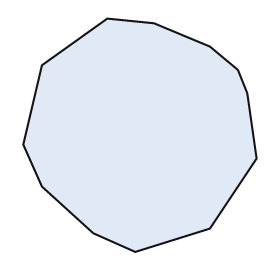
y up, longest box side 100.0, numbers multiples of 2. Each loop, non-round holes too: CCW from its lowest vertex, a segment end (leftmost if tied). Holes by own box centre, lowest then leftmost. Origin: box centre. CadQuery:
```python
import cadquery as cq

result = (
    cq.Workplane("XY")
    .moveTo(-2.0, -50.0)
    .lineTo(30.0, -40.0)
    .lineTo(50.0, -10.0)
    .lineTo(46.0, 18.0)
    .lineTo(42.0, 28.0)
    .lineTo(30.0, 38.0)
    .lineTo(6.0, 48.0)
    .lineTo(-14.0, 50.0)
    .lineTo(-42.0, 30.0)
    .lineTo(-50.0, -4.0)
    .lineTo(-42.0, -22.0)
    .lineTo(-20.0, -42.0)
    .close()
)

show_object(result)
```